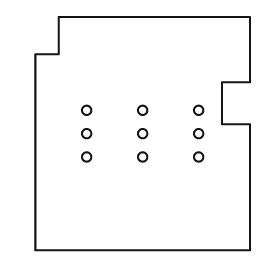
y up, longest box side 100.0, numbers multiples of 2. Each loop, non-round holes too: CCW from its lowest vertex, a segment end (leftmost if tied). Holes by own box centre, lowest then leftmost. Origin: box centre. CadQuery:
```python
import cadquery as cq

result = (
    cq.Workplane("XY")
    .moveTo(-46.0, -50.0)
    .lineTo(46.0, -50.0)
    .lineTo(46.0, 4.0)
    .lineTo(34.0, 4.0)
    .lineTo(34.0, 22.0)
    .lineTo(46.0, 22.0)
    .lineTo(46.0, 50.0)
    .lineTo(-36.0, 50.0)
    .lineTo(-36.0, 34.0)
    .lineTo(-46.0, 34.0)
    .close()
    .moveTo(-24.0, -10.0)
    .circle(2.0)
    .moveTo(0.0, -10.0)
    .circle(2.0)
    .moveTo(24.0, -10.0)
    .circle(2.0)
    .moveTo(-24.0, 0.0)
    .circle(2.0)
    .moveTo(0.0, 0.0)
    .circle(2.0)
    .moveTo(24.0, 0.0)
    .circle(2.0)
    .moveTo(-24.0, 10.0)
    .circle(2.0)
    .moveTo(0.0, 10.0)
    .circle(2.0)
    .moveTo(24.0, 10.0)
    .circle(2.0)
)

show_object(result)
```